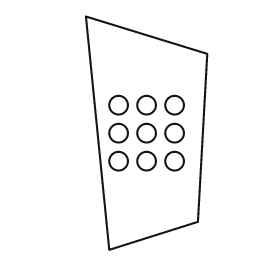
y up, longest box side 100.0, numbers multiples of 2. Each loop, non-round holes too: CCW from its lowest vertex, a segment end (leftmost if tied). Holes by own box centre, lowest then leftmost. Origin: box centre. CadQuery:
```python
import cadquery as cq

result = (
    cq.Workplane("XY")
    .moveTo(-16.0, -50.0)
    .lineTo(22.0, -38.0)
    .lineTo(26.0, 34.0)
    .lineTo(-26.0, 50.0)
    .close()
    .moveTo(-12.0, -12.0)
    .circle(4.0)
    .moveTo(0.0, -12.0)
    .circle(4.0)
    .moveTo(12.0, -12.0)
    .circle(4.0)
    .moveTo(-12.0, 0.0)
    .circle(4.0)
    .moveTo(0.0, 0.0)
    .circle(4.0)
    .moveTo(12.0, 0.0)
    .circle(4.0)
    .moveTo(-12.0, 12.0)
    .circle(4.0)
    .moveTo(0.0, 12.0)
    .circle(4.0)
    .moveTo(12.0, 12.0)
    .circle(4.0)
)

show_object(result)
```